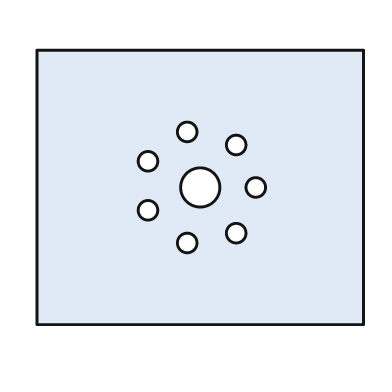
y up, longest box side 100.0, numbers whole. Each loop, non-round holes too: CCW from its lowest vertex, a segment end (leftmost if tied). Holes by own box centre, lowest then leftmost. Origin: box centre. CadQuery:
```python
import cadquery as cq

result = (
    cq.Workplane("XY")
    .moveTo(-50.0, -42.0)
    .lineTo(50.0, -42.0)
    .lineTo(50.0, 42.0)
    .lineTo(-50.0, 42.0)
    .close()
    .moveTo(-4.0, -17.0)
    .circle(3.0)
    .moveTo(11.0, -14.0)
    .circle(3.0)
    .moveTo(-16.0, -7.0)
    .circle(3.0)
    .moveTo(0.0, 0.0)
    .circle(6.0)
    .moveTo(17.0, 0.0)
    .circle(3.0)
    .moveTo(-16.0, 8.0)
    .circle(3.0)
    .moveTo(11.0, 13.0)
    .circle(3.0)
    .moveTo(-4.0, 17.0)
    .circle(3.0)
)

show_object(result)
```